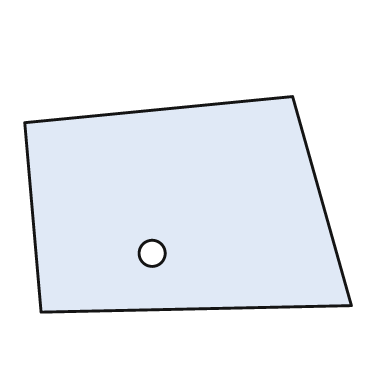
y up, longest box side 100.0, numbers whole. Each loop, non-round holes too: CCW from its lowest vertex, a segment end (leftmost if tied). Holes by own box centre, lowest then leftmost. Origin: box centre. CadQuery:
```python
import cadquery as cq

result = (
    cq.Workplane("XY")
    .moveTo(-45.0, -33.0)
    .lineTo(50.0, -31.0)
    .lineTo(32.0, 33.0)
    .lineTo(-50.0, 25.0)
    .close()
    .moveTo(-11.0, -15.0)
    .circle(4.0)
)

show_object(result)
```